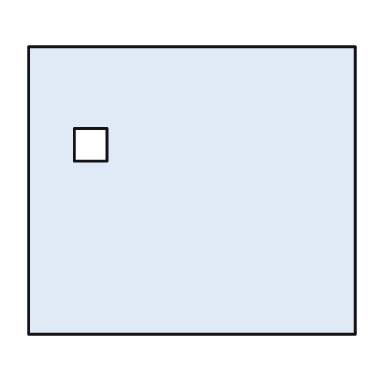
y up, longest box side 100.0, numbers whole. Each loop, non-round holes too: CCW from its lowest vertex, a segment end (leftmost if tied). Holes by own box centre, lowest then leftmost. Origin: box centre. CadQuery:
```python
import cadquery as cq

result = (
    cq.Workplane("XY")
    .moveTo(-50.0, -44.0)
    .lineTo(50.0, -44.0)
    .lineTo(50.0, 44.0)
    .lineTo(-50.0, 44.0)
    .close()
    .moveTo(-36.0, 9.0)
    .lineTo(-26.0, 9.0)
    .lineTo(-26.0, 19.0)
    .lineTo(-36.0, 19.0)
    .close()
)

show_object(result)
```